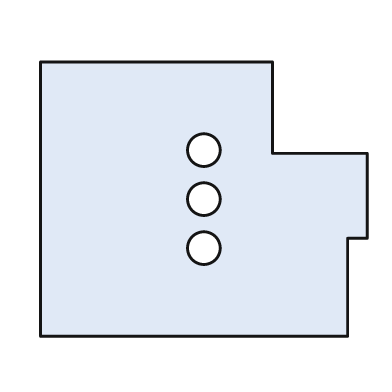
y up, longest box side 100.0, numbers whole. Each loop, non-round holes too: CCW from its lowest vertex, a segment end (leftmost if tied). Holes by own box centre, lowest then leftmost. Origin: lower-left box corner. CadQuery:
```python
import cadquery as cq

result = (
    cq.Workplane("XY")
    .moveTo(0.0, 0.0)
    .lineTo(94.0, 0.0)
    .lineTo(94.0, 30.0)
    .lineTo(100.0, 30.0)
    .lineTo(100.0, 56.0)
    .lineTo(71.0, 56.0)
    .lineTo(71.0, 84.0)
    .lineTo(0.0, 84.0)
    .close()
    .moveTo(50.0, 27.0)
    .circle(5.0)
    .moveTo(50.0, 42.0)
    .circle(5.0)
    .moveTo(50.0, 57.0)
    .circle(5.0)
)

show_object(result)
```